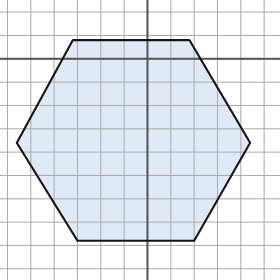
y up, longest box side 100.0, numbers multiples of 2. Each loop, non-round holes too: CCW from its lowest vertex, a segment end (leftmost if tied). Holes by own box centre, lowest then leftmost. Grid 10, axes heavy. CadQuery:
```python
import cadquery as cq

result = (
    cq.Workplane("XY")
    .moveTo(-30.0, -78.0)
    .lineTo(20.0, -78.0)
    .lineTo(44.0, -36.0)
    .lineTo(18.0, 8.0)
    .lineTo(-32.0, 8.0)
    .lineTo(-56.0, -36.0)
    .close()
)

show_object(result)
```